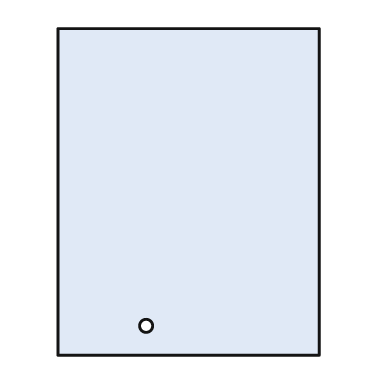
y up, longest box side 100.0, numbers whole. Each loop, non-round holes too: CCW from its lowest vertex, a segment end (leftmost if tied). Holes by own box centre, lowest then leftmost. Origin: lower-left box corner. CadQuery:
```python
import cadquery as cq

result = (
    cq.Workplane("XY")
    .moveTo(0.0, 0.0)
    .lineTo(80.0, 0.0)
    .lineTo(80.0, 100.0)
    .lineTo(0.0, 100.0)
    .close()
    .moveTo(27.0, 9.0)
    .circle(2.0)
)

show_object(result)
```